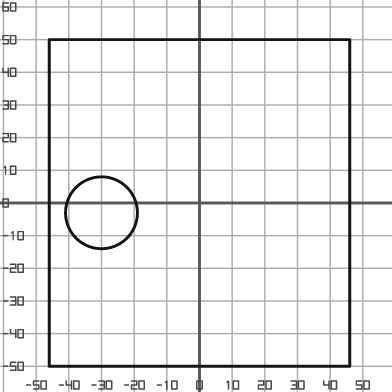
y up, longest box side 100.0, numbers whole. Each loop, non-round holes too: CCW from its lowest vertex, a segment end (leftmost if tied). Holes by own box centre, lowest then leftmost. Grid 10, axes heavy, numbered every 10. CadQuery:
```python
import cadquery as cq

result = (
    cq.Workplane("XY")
    .moveTo(-46.0, -50.0)
    .lineTo(46.0, -50.0)
    .lineTo(46.0, 50.0)
    .lineTo(-46.0, 50.0)
    .close()
    .moveTo(-30.0, -3.0)
    .circle(11.0)
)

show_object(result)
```